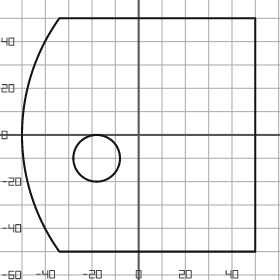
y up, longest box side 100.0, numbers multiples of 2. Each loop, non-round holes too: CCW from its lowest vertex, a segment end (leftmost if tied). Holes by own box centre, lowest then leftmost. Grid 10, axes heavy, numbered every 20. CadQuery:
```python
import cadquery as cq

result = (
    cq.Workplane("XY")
    .moveTo(-34.0, -50.0)
    .lineTo(50.0, -50.0)
    .lineTo(50.0, 50.0)
    .lineTo(-34.0, 50.0)
    .threePointArc((-50.0, 0.0), (-34.0, -50.0))
    .close()
    .moveTo(-18.0, -10.0)
    .circle(10.0)
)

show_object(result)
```